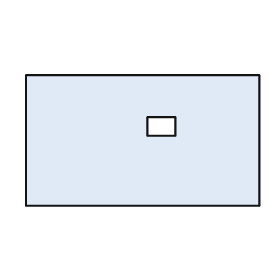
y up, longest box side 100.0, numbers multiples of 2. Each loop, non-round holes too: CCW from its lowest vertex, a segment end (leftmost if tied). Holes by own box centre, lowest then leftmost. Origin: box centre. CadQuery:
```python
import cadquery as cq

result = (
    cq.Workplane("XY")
    .moveTo(-50.0, -28.0)
    .lineTo(50.0, -28.0)
    .lineTo(50.0, 28.0)
    .lineTo(-50.0, 28.0)
    .close()
    .moveTo(2.0, 2.0)
    .lineTo(14.0, 2.0)
    .lineTo(14.0, 10.0)
    .lineTo(2.0, 10.0)
    .close()
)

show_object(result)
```